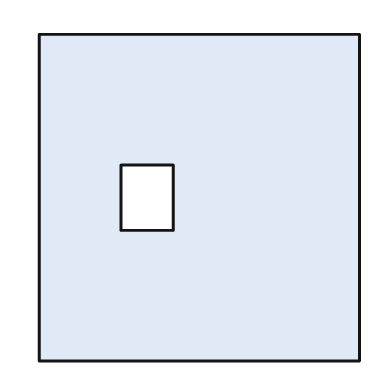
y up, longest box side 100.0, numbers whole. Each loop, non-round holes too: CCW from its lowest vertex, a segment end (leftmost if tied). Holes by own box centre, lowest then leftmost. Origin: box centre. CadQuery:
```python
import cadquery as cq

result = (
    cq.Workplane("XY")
    .moveTo(-49.0, -50.0)
    .lineTo(49.0, -50.0)
    .lineTo(49.0, 50.0)
    .lineTo(-49.0, 50.0)
    .close()
    .moveTo(-24.0, -10.0)
    .lineTo(-8.0, -10.0)
    .lineTo(-8.0, 10.0)
    .lineTo(-24.0, 10.0)
    .close()
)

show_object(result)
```